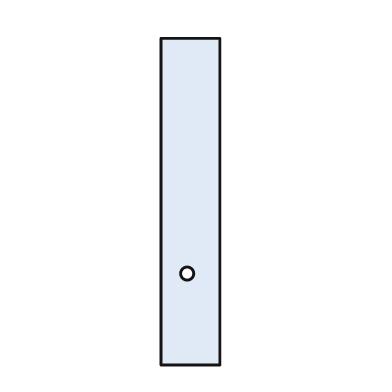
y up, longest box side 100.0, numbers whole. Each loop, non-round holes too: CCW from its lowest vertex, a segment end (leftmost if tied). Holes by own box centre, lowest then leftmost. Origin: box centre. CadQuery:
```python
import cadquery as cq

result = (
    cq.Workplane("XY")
    .moveTo(-9.0, -50.0)
    .lineTo(9.0, -50.0)
    .lineTo(9.0, 50.0)
    .lineTo(-9.0, 50.0)
    .close()
    .moveTo(-1.0, -22.0)
    .circle(2.0)
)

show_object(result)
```